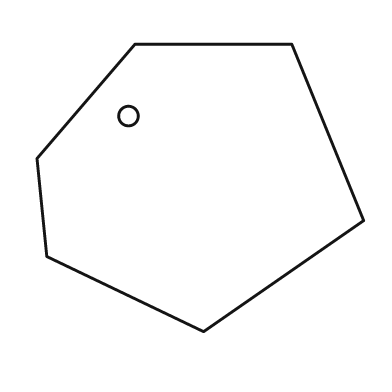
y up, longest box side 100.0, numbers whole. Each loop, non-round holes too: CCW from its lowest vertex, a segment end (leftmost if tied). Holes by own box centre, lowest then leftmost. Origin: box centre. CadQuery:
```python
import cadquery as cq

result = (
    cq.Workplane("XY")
    .moveTo(1.0, -44.0)
    .lineTo(50.0, -10.0)
    .lineTo(28.0, 44.0)
    .lineTo(-20.0, 44.0)
    .lineTo(-50.0, 9.0)
    .lineTo(-47.0, -21.0)
    .close()
    .moveTo(-22.0, 22.0)
    .circle(3.0)
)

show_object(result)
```